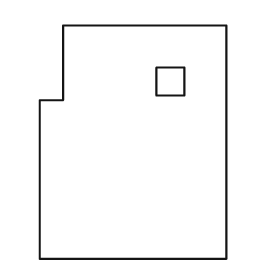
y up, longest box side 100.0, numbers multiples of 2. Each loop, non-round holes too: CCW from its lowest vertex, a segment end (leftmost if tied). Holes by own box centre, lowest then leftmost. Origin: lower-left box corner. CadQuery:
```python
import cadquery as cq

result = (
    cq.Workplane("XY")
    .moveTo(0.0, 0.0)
    .lineTo(80.0, 0.0)
    .lineTo(80.0, 100.0)
    .lineTo(10.0, 100.0)
    .lineTo(10.0, 68.0)
    .lineTo(0.0, 68.0)
    .close()
    .moveTo(50.0, 70.0)
    .lineTo(62.0, 70.0)
    .lineTo(62.0, 82.0)
    .lineTo(50.0, 82.0)
    .close()
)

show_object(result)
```